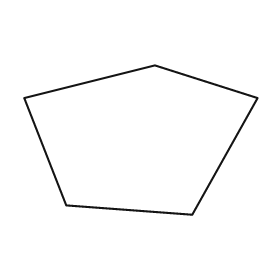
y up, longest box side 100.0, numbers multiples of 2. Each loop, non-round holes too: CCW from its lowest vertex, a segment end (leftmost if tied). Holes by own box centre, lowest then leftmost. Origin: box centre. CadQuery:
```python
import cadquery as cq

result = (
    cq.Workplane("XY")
    .moveTo(22.0, -32.0)
    .lineTo(50.0, 18.0)
    .lineTo(6.0, 32.0)
    .lineTo(-50.0, 18.0)
    .lineTo(-32.0, -28.0)
    .close()
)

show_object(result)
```